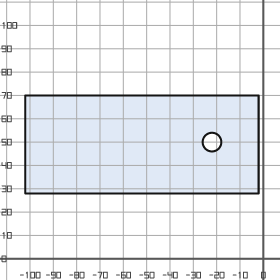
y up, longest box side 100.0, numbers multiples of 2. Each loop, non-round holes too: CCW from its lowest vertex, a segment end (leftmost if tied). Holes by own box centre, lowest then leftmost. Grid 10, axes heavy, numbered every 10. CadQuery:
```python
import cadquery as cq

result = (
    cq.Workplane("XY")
    .moveTo(-102.0, 28.0)
    .lineTo(-2.0, 28.0)
    .lineTo(-2.0, 70.0)
    .lineTo(-102.0, 70.0)
    .close()
    .moveTo(-22.0, 50.0)
    .circle(4.0)
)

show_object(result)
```